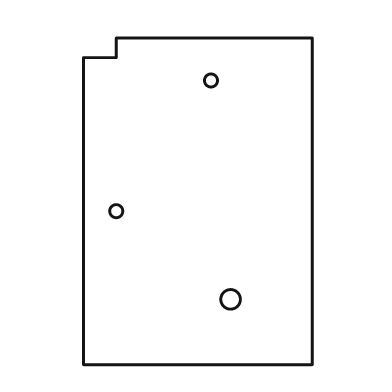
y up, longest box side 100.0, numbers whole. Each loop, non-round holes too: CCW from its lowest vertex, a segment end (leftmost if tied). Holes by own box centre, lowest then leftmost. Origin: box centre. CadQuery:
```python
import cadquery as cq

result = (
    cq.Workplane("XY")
    .moveTo(-35.0, -50.0)
    .lineTo(35.0, -50.0)
    .lineTo(35.0, 50.0)
    .lineTo(-25.0, 50.0)
    .lineTo(-25.0, 44.0)
    .lineTo(-35.0, 44.0)
    .close()
    .moveTo(10.0, -30.0)
    .circle(3.0)
    .moveTo(-25.0, -3.0)
    .circle(2.0)
    .moveTo(4.0, 37.0)
    .circle(2.0)
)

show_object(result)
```